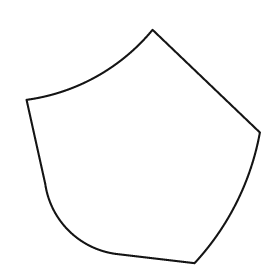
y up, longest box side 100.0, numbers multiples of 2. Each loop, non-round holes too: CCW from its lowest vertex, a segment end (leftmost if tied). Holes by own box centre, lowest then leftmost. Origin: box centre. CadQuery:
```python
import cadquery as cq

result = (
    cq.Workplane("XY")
    .moveTo(22.0, -50.0)
    .threePointArc((40.0, -24.0), (50.0, 6.0))
    .lineTo(4.0, 50.0)
    .threePointArc((-20.0, 30.0), (-50.0, 20.0))
    .lineTo(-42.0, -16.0)
    .threePointArc((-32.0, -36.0), (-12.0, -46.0))
    .close()
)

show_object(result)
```